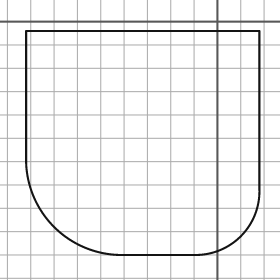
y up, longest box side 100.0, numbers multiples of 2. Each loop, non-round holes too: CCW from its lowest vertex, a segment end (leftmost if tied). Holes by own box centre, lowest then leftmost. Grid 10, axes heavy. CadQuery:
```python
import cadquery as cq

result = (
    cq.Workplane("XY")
    .moveTo(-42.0, -100.0)
    .lineTo(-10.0, -100.0)
    .threePointArc((10.0, -92.0), (18.0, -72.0))
    .lineTo(18.0, -4.0)
    .lineTo(-82.0, -4.0)
    .lineTo(-82.0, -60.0)
    .threePointArc((-70.0, -88.0), (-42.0, -100.0))
    .close()
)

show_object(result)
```